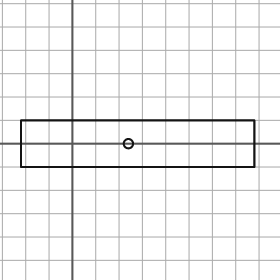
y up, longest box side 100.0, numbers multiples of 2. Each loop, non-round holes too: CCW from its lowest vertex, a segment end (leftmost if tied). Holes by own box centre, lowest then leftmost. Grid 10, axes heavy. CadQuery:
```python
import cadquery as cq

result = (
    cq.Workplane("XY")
    .moveTo(-22.0, -10.0)
    .lineTo(78.0, -10.0)
    .lineTo(78.0, 10.0)
    .lineTo(-22.0, 10.0)
    .close()
    .moveTo(24.0, 0.0)
    .circle(2.0)
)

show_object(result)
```